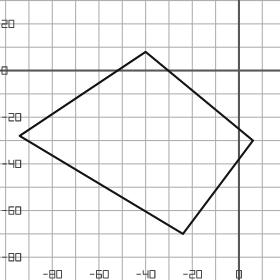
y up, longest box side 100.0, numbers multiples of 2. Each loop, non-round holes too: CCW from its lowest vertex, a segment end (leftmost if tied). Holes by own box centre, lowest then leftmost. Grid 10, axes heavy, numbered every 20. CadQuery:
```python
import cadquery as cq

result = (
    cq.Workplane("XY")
    .moveTo(-24.0, -70.0)
    .lineTo(6.0, -30.0)
    .lineTo(-40.0, 8.0)
    .lineTo(-94.0, -28.0)
    .close()
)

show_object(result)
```